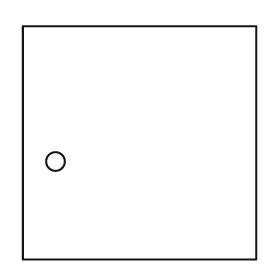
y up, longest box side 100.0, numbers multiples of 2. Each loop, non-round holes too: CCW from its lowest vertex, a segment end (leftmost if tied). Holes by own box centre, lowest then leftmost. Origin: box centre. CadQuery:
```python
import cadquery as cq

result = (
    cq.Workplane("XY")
    .moveTo(-50.0, -50.0)
    .lineTo(50.0, -50.0)
    .lineTo(50.0, 50.0)
    .lineTo(-50.0, 50.0)
    .close()
    .moveTo(-36.0, -8.0)
    .circle(4.0)
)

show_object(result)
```